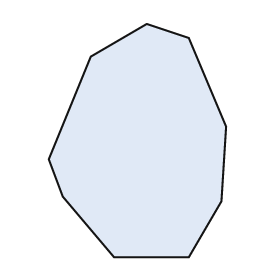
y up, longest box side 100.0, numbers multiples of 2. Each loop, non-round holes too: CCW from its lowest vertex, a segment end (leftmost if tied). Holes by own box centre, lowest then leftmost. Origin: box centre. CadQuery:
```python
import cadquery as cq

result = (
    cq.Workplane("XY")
    .moveTo(-10.0, -50.0)
    .lineTo(22.0, -50.0)
    .lineTo(36.0, -26.0)
    .lineTo(38.0, 6.0)
    .lineTo(22.0, 44.0)
    .lineTo(4.0, 50.0)
    .lineTo(-20.0, 36.0)
    .lineTo(-38.0, -8.0)
    .lineTo(-32.0, -24.0)
    .close()
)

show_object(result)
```